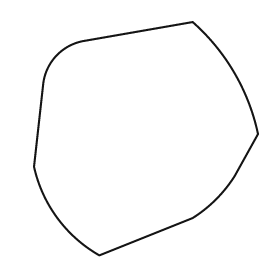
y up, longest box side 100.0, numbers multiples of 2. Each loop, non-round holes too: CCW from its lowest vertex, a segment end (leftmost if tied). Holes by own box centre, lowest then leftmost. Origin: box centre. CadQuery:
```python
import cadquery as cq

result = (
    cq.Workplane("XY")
    .moveTo(-20.0, -50.0)
    .lineTo(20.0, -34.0)
    .threePointArc((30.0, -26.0), (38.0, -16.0))
    .lineTo(48.0, 2.0)
    .threePointArc((38.0, 28.0), (20.0, 50.0))
    .lineTo(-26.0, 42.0)
    .threePointArc((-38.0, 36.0), (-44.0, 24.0))
    .lineTo(-48.0, -12.0)
    .threePointArc((-38.0, -34.0), (-20.0, -50.0))
    .close()
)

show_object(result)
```